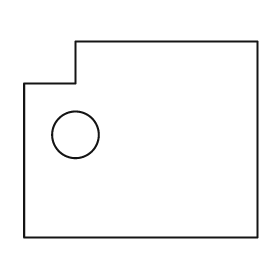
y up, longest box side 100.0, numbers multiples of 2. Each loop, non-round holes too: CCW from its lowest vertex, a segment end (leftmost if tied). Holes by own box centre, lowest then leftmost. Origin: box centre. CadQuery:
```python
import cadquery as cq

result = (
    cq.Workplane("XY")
    .moveTo(-50.0, -42.0)
    .lineTo(50.0, -42.0)
    .lineTo(50.0, 42.0)
    .lineTo(-28.0, 42.0)
    .lineTo(-28.0, 24.0)
    .lineTo(-50.0, 24.0)
    .close()
    .moveTo(-28.0, 2.0)
    .circle(10.0)
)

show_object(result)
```